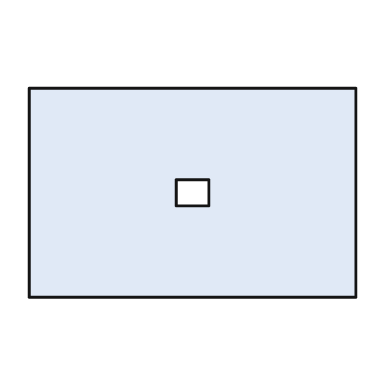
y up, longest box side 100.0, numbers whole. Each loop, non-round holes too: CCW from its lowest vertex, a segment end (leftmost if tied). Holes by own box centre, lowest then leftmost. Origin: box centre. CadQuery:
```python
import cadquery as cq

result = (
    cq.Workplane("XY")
    .moveTo(-50.0, -32.0)
    .lineTo(50.0, -32.0)
    .lineTo(50.0, 32.0)
    .lineTo(-50.0, 32.0)
    .close()
    .moveTo(-5.0, -4.0)
    .lineTo(5.0, -4.0)
    .lineTo(5.0, 4.0)
    .lineTo(-5.0, 4.0)
    .close()
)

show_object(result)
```